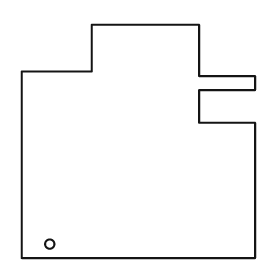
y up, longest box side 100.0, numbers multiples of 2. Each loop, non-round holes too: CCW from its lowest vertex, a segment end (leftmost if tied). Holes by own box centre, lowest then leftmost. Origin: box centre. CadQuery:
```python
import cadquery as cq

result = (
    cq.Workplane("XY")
    .moveTo(-50.0, -50.0)
    .lineTo(50.0, -50.0)
    .lineTo(50.0, 8.0)
    .lineTo(26.0, 8.0)
    .lineTo(26.0, 22.0)
    .lineTo(50.0, 22.0)
    .lineTo(50.0, 28.0)
    .lineTo(26.0, 28.0)
    .lineTo(26.0, 50.0)
    .lineTo(-20.0, 50.0)
    .lineTo(-20.0, 30.0)
    .lineTo(-50.0, 30.0)
    .close()
    .moveTo(-38.0, -44.0)
    .circle(2.0)
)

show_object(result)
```